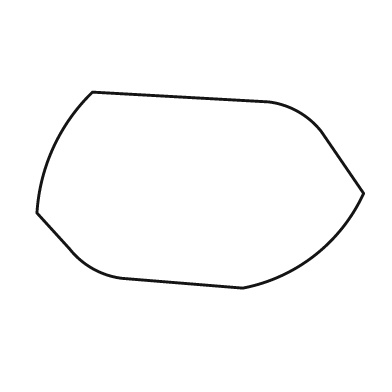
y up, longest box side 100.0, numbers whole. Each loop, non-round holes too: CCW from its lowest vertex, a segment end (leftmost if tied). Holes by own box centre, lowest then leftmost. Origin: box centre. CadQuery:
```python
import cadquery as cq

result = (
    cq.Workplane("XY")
    .moveTo(13.0, -30.0)
    .threePointArc((35.0, -20.0), (50.0, -1.0))
    .lineTo(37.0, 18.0)
    .threePointArc((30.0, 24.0), (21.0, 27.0))
    .lineTo(-33.0, 30.0)
    .threePointArc((-45.0, 13.0), (-50.0, -7.0))
    .lineTo(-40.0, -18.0)
    .threePointArc((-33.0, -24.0), (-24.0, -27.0))
    .close()
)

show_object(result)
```